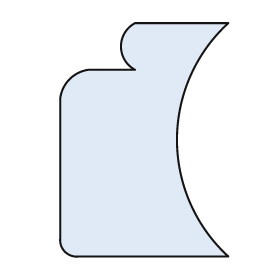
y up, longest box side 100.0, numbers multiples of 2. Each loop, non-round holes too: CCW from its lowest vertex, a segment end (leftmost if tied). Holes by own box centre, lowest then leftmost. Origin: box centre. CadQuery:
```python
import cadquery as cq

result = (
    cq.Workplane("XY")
    .moveTo(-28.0, -50.0)
    .lineTo(36.0, -50.0)
    .threePointArc((14.0, 0.0), (36.0, 50.0))
    .lineTo(-4.0, 50.0)
    .threePointArc((-10.0, 40.0), (-4.0, 30.0))
    .lineTo(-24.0, 30.0)
    .threePointArc((-32.0, 26.0), (-36.0, 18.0))
    .lineTo(-36.0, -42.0)
    .threePointArc((-34.0, -48.0), (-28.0, -50.0))
    .close()
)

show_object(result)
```